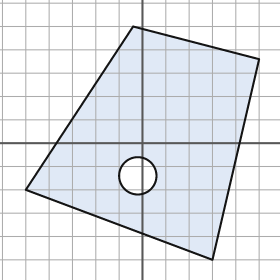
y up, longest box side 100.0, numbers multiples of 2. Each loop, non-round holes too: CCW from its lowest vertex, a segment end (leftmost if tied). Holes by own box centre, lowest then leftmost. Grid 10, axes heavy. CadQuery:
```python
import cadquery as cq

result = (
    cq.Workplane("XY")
    .moveTo(30.0, -50.0)
    .lineTo(50.0, 36.0)
    .lineTo(-4.0, 50.0)
    .lineTo(-50.0, -20.0)
    .close()
    .moveTo(-2.0, -14.0)
    .circle(8.0)
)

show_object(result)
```